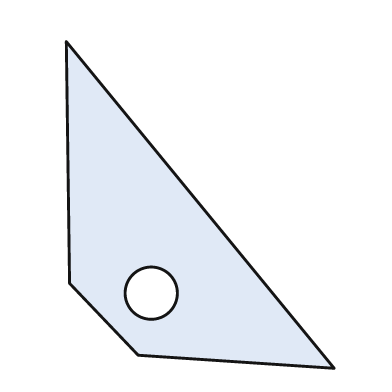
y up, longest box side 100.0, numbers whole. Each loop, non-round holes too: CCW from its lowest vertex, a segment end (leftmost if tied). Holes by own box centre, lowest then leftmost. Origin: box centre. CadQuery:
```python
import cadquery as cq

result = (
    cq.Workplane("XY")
    .moveTo(41.0, -50.0)
    .lineTo(-41.0, 50.0)
    .lineTo(-40.0, -24.0)
    .lineTo(-19.0, -46.0)
    .close()
    .moveTo(-15.0, -27.0)
    .circle(8.0)
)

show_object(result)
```